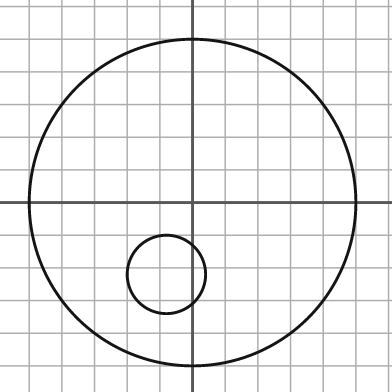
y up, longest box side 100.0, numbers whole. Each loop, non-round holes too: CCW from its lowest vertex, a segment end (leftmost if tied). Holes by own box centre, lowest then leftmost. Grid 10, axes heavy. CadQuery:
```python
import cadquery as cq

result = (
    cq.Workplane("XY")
    .moveTo(0.0, 0.0)
    .circle(50.0)
    .moveTo(-8.0, -22.0)
    .circle(12.0)
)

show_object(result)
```